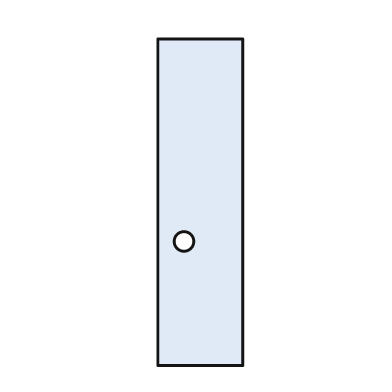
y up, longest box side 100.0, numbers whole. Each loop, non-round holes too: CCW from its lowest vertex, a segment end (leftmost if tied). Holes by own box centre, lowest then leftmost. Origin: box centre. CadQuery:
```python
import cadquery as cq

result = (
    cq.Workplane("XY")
    .moveTo(-13.0, -50.0)
    .lineTo(13.0, -50.0)
    .lineTo(13.0, 50.0)
    .lineTo(-13.0, 50.0)
    .close()
    .moveTo(-5.0, -12.0)
    .circle(3.0)
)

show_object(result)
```